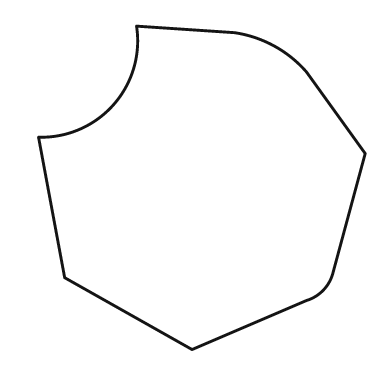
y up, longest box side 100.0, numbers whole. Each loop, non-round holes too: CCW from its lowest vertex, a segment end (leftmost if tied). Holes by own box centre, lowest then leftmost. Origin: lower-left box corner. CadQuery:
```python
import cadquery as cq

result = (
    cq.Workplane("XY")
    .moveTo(47.0, 0.0)
    .lineTo(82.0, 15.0)
    .threePointArc((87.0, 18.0), (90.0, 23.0))
    .lineTo(100.0, 60.0)
    .lineTo(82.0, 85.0)
    .threePointArc((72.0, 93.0), (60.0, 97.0))
    .lineTo(30.0, 99.0)
    .threePointArc((23.0, 75.0), (0.0, 65.0))
    .lineTo(8.0, 22.0)
    .close()
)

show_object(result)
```